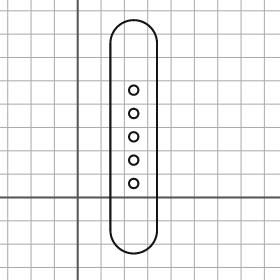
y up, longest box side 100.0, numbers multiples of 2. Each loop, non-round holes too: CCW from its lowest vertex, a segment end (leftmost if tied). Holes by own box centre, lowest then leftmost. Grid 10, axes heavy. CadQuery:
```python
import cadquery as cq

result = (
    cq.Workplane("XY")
    .moveTo(14.0, -14.0)
    .threePointArc((24.0, -24.0), (34.0, -14.0))
    .lineTo(34.0, 66.0)
    .threePointArc((24.0, 76.0), (14.0, 66.0))
    .close()
    .moveTo(24.0, 6.0)
    .circle(2.0)
    .moveTo(24.0, 16.0)
    .circle(2.0)
    .moveTo(24.0, 26.0)
    .circle(2.0)
    .moveTo(24.0, 36.0)
    .circle(2.0)
    .moveTo(24.0, 46.0)
    .circle(2.0)
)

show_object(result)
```